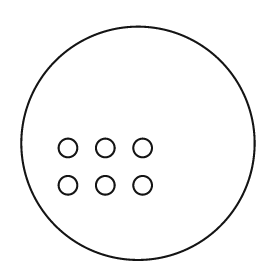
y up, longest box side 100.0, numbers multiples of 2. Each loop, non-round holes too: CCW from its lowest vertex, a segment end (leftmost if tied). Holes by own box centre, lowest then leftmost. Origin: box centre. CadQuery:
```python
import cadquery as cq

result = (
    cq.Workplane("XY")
    .moveTo(0.0, 0.0)
    .circle(50.0)
    .moveTo(-30.0, -18.0)
    .circle(4.0)
    .moveTo(-14.0, -18.0)
    .circle(4.0)
    .moveTo(2.0, -18.0)
    .circle(4.0)
    .moveTo(-30.0, -2.0)
    .circle(4.0)
    .moveTo(-14.0, -2.0)
    .circle(4.0)
    .moveTo(2.0, -2.0)
    .circle(4.0)
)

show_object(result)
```